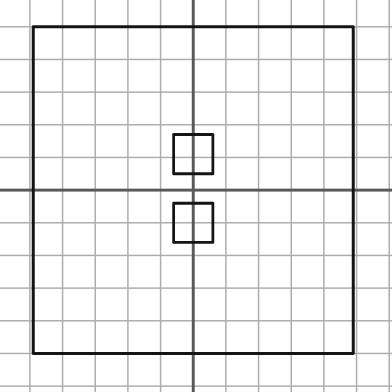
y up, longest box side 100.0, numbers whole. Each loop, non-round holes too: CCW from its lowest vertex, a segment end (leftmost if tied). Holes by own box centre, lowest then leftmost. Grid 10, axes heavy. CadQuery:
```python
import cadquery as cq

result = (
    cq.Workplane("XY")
    .moveTo(-49.0, -50.0)
    .lineTo(49.0, -50.0)
    .lineTo(49.0, 50.0)
    .lineTo(-49.0, 50.0)
    .close()
    .moveTo(-6.0, -16.0)
    .lineTo(6.0, -16.0)
    .lineTo(6.0, -4.0)
    .lineTo(-6.0, -4.0)
    .close()
    .moveTo(-6.0, 5.0)
    .lineTo(6.0, 5.0)
    .lineTo(6.0, 17.0)
    .lineTo(-6.0, 17.0)
    .close()
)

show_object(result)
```